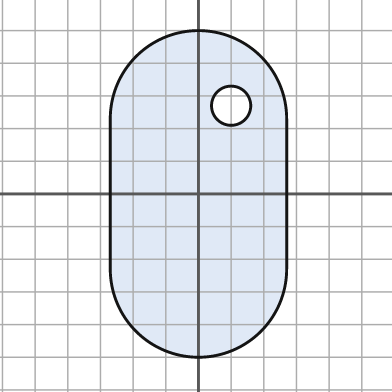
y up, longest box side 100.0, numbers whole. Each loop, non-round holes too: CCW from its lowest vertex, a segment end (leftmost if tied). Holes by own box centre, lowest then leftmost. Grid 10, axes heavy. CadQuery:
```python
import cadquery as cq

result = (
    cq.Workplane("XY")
    .moveTo(-27.0, -23.0)
    .threePointArc((0.0, -50.0), (27.0, -23.0))
    .lineTo(27.0, 23.0)
    .threePointArc((0.0, 50.0), (-27.0, 23.0))
    .close()
    .moveTo(10.0, 27.0)
    .circle(6.0)
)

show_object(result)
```